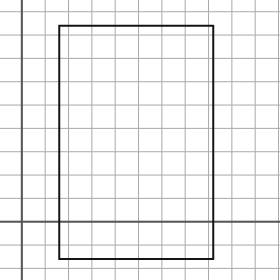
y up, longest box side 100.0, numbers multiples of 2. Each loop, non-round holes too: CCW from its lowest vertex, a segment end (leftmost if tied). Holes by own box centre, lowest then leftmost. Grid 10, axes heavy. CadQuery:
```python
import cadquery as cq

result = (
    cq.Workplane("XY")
    .moveTo(16.0, -16.0)
    .lineTo(82.0, -16.0)
    .lineTo(82.0, 84.0)
    .lineTo(16.0, 84.0)
    .close()
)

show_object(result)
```